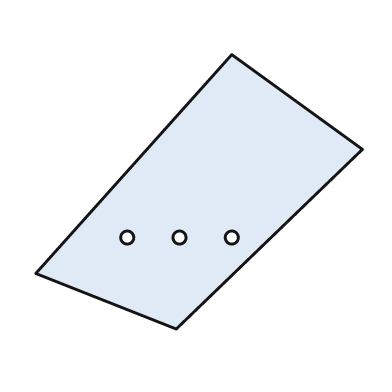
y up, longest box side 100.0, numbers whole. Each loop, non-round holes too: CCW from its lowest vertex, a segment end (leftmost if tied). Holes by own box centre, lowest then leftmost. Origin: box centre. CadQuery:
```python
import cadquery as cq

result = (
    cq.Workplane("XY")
    .moveTo(-7.0, -42.0)
    .lineTo(50.0, 13.0)
    .lineTo(10.0, 42.0)
    .lineTo(-50.0, -25.0)
    .close()
    .moveTo(-22.0, -14.0)
    .circle(2.0)
    .moveTo(-6.0, -14.0)
    .circle(2.0)
    .moveTo(10.0, -14.0)
    .circle(2.0)
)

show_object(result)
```